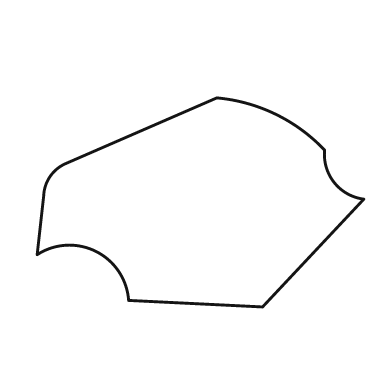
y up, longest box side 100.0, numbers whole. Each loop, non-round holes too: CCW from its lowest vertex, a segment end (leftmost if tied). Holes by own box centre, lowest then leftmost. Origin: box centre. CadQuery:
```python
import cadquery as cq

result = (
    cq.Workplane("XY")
    .moveTo(19.0, -32.0)
    .lineTo(50.0, 1.0)
    .threePointArc((41.0, 6.0), (38.0, 16.0))
    .threePointArc((23.0, 27.0), (5.0, 32.0))
    .lineTo(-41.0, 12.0)
    .threePointArc((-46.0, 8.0), (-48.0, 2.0))
    .lineTo(-50.0, -16.0)
    .threePointArc((-32.0, -15.0), (-22.0, -30.0))
    .close()
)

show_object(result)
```